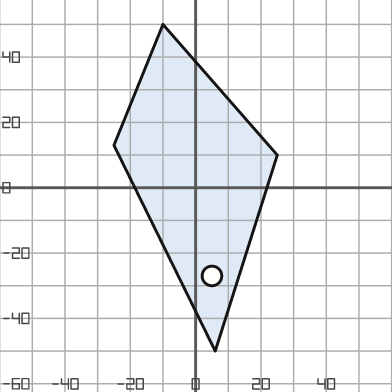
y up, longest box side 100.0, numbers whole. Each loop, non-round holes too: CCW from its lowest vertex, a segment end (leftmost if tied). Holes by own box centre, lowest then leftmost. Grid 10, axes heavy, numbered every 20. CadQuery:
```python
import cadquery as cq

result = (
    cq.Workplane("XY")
    .moveTo(6.0, -50.0)
    .lineTo(25.0, 10.0)
    .lineTo(-10.0, 50.0)
    .lineTo(-25.0, 13.0)
    .close()
    .moveTo(5.0, -27.0)
    .circle(3.0)
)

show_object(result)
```